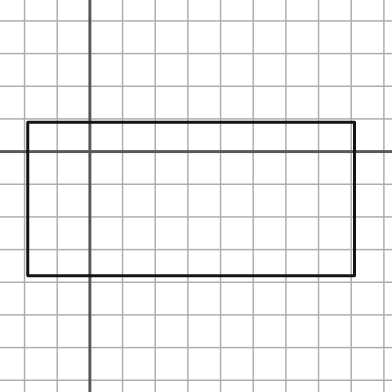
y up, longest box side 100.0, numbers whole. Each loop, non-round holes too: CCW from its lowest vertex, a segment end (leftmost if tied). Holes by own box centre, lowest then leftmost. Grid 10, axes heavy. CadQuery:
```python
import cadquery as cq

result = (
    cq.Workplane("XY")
    .moveTo(-19.0, -38.0)
    .lineTo(81.0, -38.0)
    .lineTo(81.0, 9.0)
    .lineTo(-19.0, 9.0)
    .close()
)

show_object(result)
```